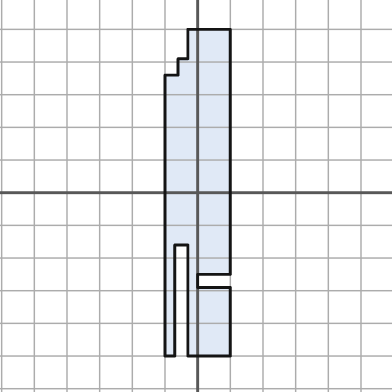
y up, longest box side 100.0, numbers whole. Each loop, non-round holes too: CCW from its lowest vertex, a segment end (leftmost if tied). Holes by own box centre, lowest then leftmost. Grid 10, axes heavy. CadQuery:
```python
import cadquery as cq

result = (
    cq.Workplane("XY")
    .moveTo(-10.0, -50.0)
    .lineTo(-7.0, -50.0)
    .lineTo(-7.0, -16.0)
    .lineTo(-3.0, -16.0)
    .lineTo(-3.0, -50.0)
    .lineTo(10.0, -50.0)
    .lineTo(10.0, -29.0)
    .lineTo(0.0, -29.0)
    .lineTo(0.0, -25.0)
    .lineTo(10.0, -25.0)
    .lineTo(10.0, 50.0)
    .lineTo(-3.0, 50.0)
    .lineTo(-3.0, 41.0)
    .lineTo(-6.0, 41.0)
    .lineTo(-6.0, 36.0)
    .lineTo(-10.0, 36.0)
    .close()
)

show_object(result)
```